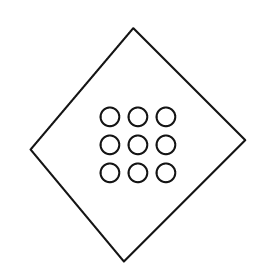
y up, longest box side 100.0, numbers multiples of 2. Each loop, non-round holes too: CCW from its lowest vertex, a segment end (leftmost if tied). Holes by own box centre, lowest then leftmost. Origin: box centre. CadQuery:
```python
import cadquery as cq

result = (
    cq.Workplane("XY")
    .moveTo(-6.0, -50.0)
    .lineTo(46.0, 2.0)
    .lineTo(-2.0, 50.0)
    .lineTo(-46.0, -2.0)
    .close()
    .moveTo(-12.0, -12.0)
    .circle(4.0)
    .moveTo(0.0, -12.0)
    .circle(4.0)
    .moveTo(12.0, -12.0)
    .circle(4.0)
    .moveTo(-12.0, 0.0)
    .circle(4.0)
    .moveTo(0.0, 0.0)
    .circle(4.0)
    .moveTo(12.0, 0.0)
    .circle(4.0)
    .moveTo(-12.0, 12.0)
    .circle(4.0)
    .moveTo(0.0, 12.0)
    .circle(4.0)
    .moveTo(12.0, 12.0)
    .circle(4.0)
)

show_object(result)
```